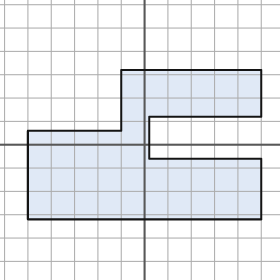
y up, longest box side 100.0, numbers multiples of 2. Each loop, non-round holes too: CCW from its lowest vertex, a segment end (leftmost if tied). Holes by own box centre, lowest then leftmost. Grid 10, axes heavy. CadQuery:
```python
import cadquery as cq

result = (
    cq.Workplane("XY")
    .moveTo(-50.0, -32.0)
    .lineTo(50.0, -32.0)
    .lineTo(50.0, -6.0)
    .lineTo(2.0, -6.0)
    .lineTo(2.0, 12.0)
    .lineTo(50.0, 12.0)
    .lineTo(50.0, 32.0)
    .lineTo(-10.0, 32.0)
    .lineTo(-10.0, 6.0)
    .lineTo(-50.0, 6.0)
    .close()
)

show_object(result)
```